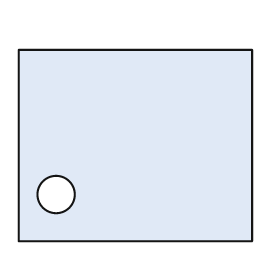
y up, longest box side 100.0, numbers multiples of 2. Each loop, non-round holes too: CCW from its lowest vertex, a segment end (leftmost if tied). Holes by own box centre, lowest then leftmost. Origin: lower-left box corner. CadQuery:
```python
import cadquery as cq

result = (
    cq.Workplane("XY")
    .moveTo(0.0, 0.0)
    .lineTo(100.0, 0.0)
    .lineTo(100.0, 82.0)
    .lineTo(0.0, 82.0)
    .close()
    .moveTo(16.0, 20.0)
    .circle(8.0)
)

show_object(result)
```